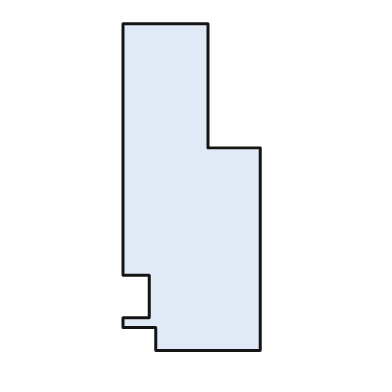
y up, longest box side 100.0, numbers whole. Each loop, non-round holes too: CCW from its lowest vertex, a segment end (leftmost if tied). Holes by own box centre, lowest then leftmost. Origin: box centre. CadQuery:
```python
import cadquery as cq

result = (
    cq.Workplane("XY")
    .moveTo(-11.0, -50.0)
    .lineTo(21.0, -50.0)
    .lineTo(21.0, 12.0)
    .lineTo(5.0, 12.0)
    .lineTo(5.0, 50.0)
    .lineTo(-21.0, 50.0)
    .lineTo(-21.0, -27.0)
    .lineTo(-13.0, -27.0)
    .lineTo(-13.0, -40.0)
    .lineTo(-21.0, -40.0)
    .lineTo(-21.0, -43.0)
    .lineTo(-11.0, -43.0)
    .close()
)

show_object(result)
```